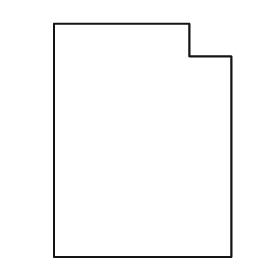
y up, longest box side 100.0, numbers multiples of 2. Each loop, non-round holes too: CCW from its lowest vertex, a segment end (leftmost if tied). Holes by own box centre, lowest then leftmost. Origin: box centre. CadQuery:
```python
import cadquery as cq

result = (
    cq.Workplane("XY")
    .moveTo(-38.0, -50.0)
    .lineTo(38.0, -50.0)
    .lineTo(38.0, 36.0)
    .lineTo(20.0, 36.0)
    .lineTo(20.0, 50.0)
    .lineTo(-38.0, 50.0)
    .close()
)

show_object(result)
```